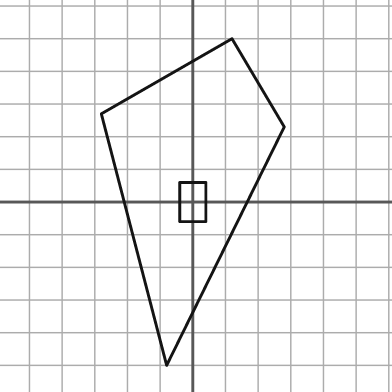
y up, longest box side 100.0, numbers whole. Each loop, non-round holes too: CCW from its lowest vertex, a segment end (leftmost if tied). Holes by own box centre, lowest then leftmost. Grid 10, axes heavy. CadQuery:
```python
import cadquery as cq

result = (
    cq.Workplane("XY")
    .moveTo(-8.0, -50.0)
    .lineTo(28.0, 23.0)
    .lineTo(12.0, 50.0)
    .lineTo(-28.0, 27.0)
    .close()
    .moveTo(-4.0, -6.0)
    .lineTo(4.0, -6.0)
    .lineTo(4.0, 6.0)
    .lineTo(-4.0, 6.0)
    .close()
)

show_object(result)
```